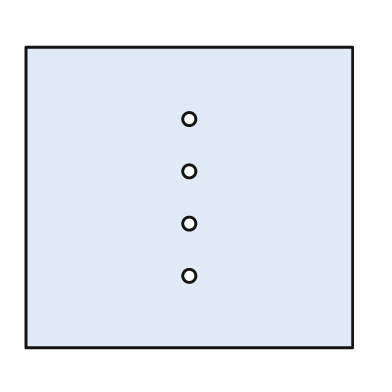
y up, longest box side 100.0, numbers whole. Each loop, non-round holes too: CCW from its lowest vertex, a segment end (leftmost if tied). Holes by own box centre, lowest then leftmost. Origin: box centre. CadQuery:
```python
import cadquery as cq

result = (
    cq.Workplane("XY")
    .moveTo(-50.0, -46.0)
    .lineTo(50.0, -46.0)
    .lineTo(50.0, 46.0)
    .lineTo(-50.0, 46.0)
    .close()
    .moveTo(0.0, -24.0)
    .circle(2.0)
    .moveTo(0.0, -8.0)
    .circle(2.0)
    .moveTo(0.0, 8.0)
    .circle(2.0)
    .moveTo(0.0, 24.0)
    .circle(2.0)
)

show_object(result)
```